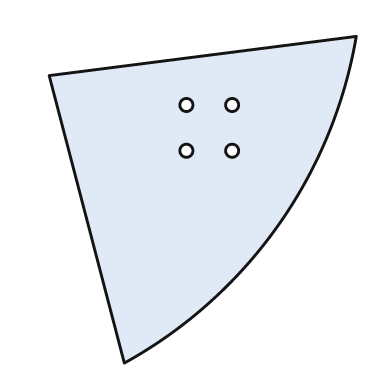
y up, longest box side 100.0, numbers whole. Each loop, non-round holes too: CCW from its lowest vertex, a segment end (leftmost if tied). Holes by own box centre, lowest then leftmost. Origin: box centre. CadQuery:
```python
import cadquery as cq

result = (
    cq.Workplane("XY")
    .moveTo(-24.0, -50.0)
    .threePointArc((23.0, -8.0), (47.0, 50.0))
    .lineTo(-47.0, 38.0)
    .close()
    .moveTo(-5.0, 15.0)
    .circle(2.0)
    .moveTo(9.0, 15.0)
    .circle(2.0)
    .moveTo(-5.0, 29.0)
    .circle(2.0)
    .moveTo(9.0, 29.0)
    .circle(2.0)
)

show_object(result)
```